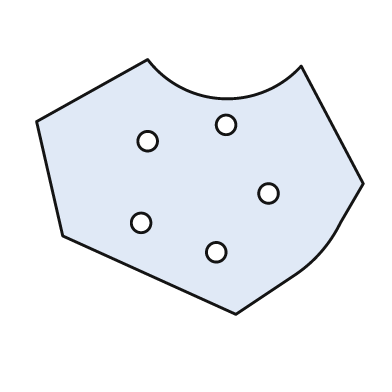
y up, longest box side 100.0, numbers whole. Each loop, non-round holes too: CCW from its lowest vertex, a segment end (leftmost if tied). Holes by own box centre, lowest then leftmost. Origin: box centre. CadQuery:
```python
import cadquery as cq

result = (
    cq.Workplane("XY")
    .moveTo(11.0, -39.0)
    .lineTo(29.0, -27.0)
    .threePointArc((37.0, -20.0), (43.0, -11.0))
    .lineTo(50.0, 1.0)
    .lineTo(31.0, 37.0)
    .threePointArc((7.0, 27.0), (-16.0, 39.0))
    .lineTo(-50.0, 20.0)
    .lineTo(-42.0, -15.0)
    .close()
    .moveTo(5.0, -20.0)
    .circle(3.0)
    .moveTo(-18.0, -11.0)
    .circle(3.0)
    .moveTo(21.0, -2.0)
    .circle(3.0)
    .moveTo(-16.0, 14.0)
    .circle(3.0)
    .moveTo(8.0, 19.0)
    .circle(3.0)
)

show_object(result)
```